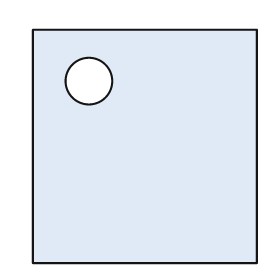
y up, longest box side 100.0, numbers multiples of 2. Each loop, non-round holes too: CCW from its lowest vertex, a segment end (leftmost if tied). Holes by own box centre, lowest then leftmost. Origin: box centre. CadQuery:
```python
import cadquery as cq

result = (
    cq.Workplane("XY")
    .moveTo(-48.0, -50.0)
    .lineTo(48.0, -50.0)
    .lineTo(48.0, 50.0)
    .lineTo(-48.0, 50.0)
    .close()
    .moveTo(-24.0, 28.0)
    .circle(10.0)
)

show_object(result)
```